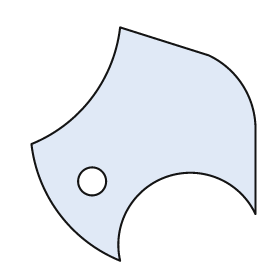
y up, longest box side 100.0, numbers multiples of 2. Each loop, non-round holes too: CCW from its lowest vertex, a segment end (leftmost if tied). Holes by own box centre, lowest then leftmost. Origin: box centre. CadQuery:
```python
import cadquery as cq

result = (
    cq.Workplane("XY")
    .moveTo(-10.0, -50.0)
    .threePointArc((10.0, -14.0), (48.0, -30.0))
    .lineTo(48.0, 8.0)
    .threePointArc((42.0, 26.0), (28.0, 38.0))
    .lineTo(-10.0, 50.0)
    .threePointArc((-22.0, 20.0), (-48.0, 0.0))
    .threePointArc((-36.0, -30.0), (-10.0, -50.0))
    .close()
    .moveTo(-22.0, -16.0)
    .circle(6.0)
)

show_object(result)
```